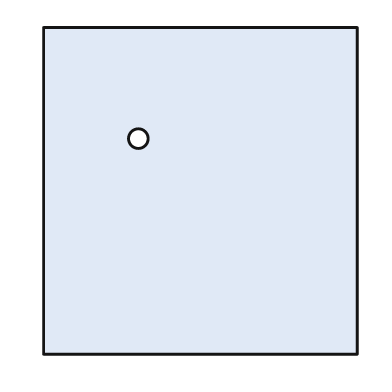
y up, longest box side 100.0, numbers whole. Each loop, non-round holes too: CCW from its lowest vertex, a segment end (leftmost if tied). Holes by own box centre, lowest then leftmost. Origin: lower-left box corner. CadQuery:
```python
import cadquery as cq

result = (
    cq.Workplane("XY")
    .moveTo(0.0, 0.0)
    .lineTo(96.0, 0.0)
    .lineTo(96.0, 100.0)
    .lineTo(0.0, 100.0)
    .close()
    .moveTo(29.0, 66.0)
    .circle(3.0)
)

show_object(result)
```